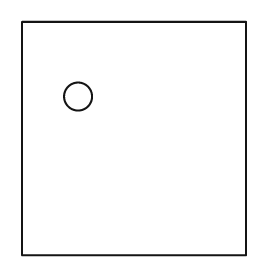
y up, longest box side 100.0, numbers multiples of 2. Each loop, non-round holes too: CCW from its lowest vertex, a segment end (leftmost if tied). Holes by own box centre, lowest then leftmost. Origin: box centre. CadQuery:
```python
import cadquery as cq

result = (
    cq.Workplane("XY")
    .moveTo(-48.0, -50.0)
    .lineTo(48.0, -50.0)
    .lineTo(48.0, 50.0)
    .lineTo(-48.0, 50.0)
    .close()
    .moveTo(-24.0, 18.0)
    .circle(6.0)
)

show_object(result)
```